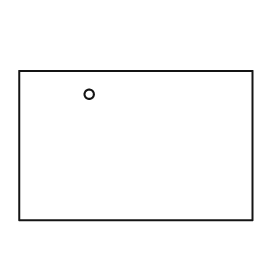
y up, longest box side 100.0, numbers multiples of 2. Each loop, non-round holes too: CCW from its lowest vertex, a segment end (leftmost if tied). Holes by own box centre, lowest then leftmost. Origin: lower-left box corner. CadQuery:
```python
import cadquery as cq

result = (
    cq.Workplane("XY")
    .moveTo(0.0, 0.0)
    .lineTo(100.0, 0.0)
    .lineTo(100.0, 64.0)
    .lineTo(0.0, 64.0)
    .close()
    .moveTo(30.0, 54.0)
    .circle(2.0)
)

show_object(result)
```